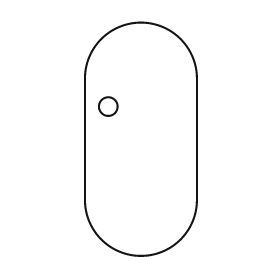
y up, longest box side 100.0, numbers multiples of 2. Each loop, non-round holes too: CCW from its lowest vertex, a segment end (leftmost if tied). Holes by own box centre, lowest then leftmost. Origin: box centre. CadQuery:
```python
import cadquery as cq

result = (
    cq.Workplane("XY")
    .moveTo(-24.0, -26.0)
    .threePointArc((0.0, -50.0), (24.0, -26.0))
    .lineTo(24.0, 26.0)
    .threePointArc((0.0, 50.0), (-24.0, 26.0))
    .close()
    .moveTo(-14.0, 14.0)
    .circle(4.0)
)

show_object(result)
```